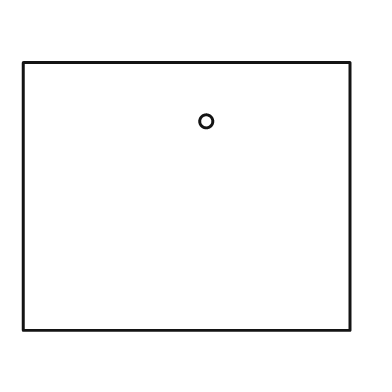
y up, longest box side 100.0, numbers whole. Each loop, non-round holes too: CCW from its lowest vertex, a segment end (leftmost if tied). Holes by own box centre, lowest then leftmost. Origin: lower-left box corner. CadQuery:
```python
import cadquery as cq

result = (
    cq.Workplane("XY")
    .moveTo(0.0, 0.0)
    .lineTo(100.0, 0.0)
    .lineTo(100.0, 82.0)
    .lineTo(0.0, 82.0)
    .close()
    .moveTo(56.0, 64.0)
    .circle(2.0)
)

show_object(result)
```